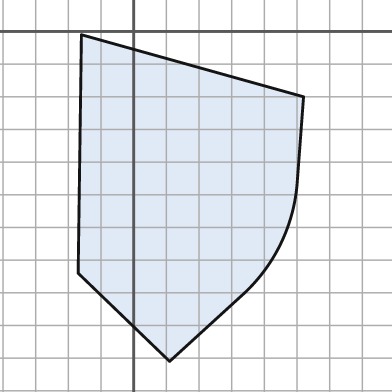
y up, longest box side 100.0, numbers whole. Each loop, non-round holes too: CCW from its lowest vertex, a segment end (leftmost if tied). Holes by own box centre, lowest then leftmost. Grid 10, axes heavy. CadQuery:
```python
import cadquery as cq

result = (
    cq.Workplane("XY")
    .moveTo(11.0, -101.0)
    .lineTo(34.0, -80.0)
    .threePointArc((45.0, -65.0), (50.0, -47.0))
    .lineTo(52.0, -20.0)
    .lineTo(-16.0, -1.0)
    .lineTo(-17.0, -74.0)
    .close()
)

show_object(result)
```